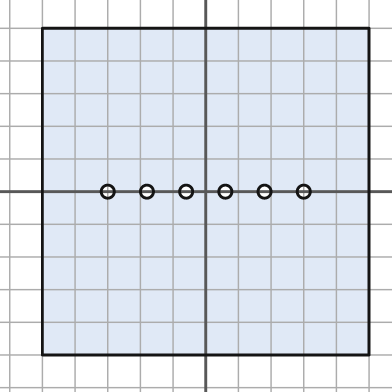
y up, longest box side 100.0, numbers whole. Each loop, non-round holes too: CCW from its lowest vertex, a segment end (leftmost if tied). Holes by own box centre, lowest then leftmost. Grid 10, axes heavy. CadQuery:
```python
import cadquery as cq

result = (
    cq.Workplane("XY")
    .moveTo(-50.0, -50.0)
    .lineTo(50.0, -50.0)
    .lineTo(50.0, 50.0)
    .lineTo(-50.0, 50.0)
    .close()
    .moveTo(-30.0, 0.0)
    .circle(2.0)
    .moveTo(-18.0, 0.0)
    .circle(2.0)
    .moveTo(-6.0, 0.0)
    .circle(2.0)
    .moveTo(6.0, 0.0)
    .circle(2.0)
    .moveTo(18.0, 0.0)
    .circle(2.0)
    .moveTo(30.0, 0.0)
    .circle(2.0)
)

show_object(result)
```